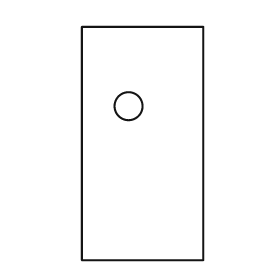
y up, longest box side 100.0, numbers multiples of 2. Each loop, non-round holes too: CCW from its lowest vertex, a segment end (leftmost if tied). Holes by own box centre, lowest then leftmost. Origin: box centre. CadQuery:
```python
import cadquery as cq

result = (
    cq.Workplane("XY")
    .moveTo(-26.0, -50.0)
    .lineTo(26.0, -50.0)
    .lineTo(26.0, 50.0)
    .lineTo(-26.0, 50.0)
    .close()
    .moveTo(-6.0, 16.0)
    .circle(6.0)
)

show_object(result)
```